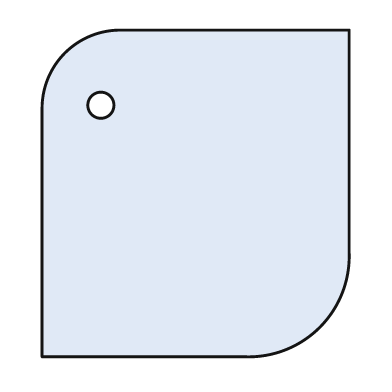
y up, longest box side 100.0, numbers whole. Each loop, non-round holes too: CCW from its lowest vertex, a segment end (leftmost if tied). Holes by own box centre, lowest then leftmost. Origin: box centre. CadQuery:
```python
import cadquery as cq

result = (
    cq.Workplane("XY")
    .moveTo(-47.0, -50.0)
    .lineTo(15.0, -50.0)
    .threePointArc((38.0, -41.0), (47.0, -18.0))
    .lineTo(47.0, 50.0)
    .lineTo(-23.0, 50.0)
    .threePointArc((-40.0, 43.0), (-47.0, 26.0))
    .close()
    .moveTo(-29.0, 27.0)
    .circle(4.0)
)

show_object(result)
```